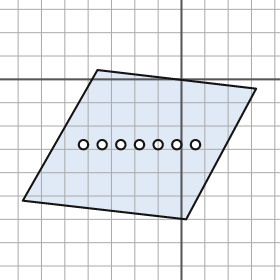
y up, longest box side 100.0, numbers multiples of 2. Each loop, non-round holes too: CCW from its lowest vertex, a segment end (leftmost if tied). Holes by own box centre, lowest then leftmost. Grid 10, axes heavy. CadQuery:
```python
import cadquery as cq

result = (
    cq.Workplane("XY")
    .moveTo(2.0, -60.0)
    .lineTo(32.0, -4.0)
    .lineTo(-36.0, 4.0)
    .lineTo(-68.0, -52.0)
    .close()
    .moveTo(-42.0, -28.0)
    .circle(2.0)
    .moveTo(-34.0, -28.0)
    .circle(2.0)
    .moveTo(-26.0, -28.0)
    .circle(2.0)
    .moveTo(-18.0, -28.0)
    .circle(2.0)
    .moveTo(-10.0, -28.0)
    .circle(2.0)
    .moveTo(-2.0, -28.0)
    .circle(2.0)
    .moveTo(6.0, -28.0)
    .circle(2.0)
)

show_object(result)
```